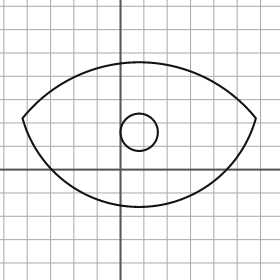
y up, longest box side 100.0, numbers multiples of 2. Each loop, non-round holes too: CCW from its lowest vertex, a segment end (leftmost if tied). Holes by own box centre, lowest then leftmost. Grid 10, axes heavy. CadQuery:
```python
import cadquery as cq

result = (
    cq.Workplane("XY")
    .moveTo(-42.0, 22.0)
    .threePointArc((8.0, -16.0), (58.0, 22.0))
    .threePointArc((8.0, 46.0), (-42.0, 22.0))
    .close()
    .moveTo(8.0, 16.0)
    .circle(8.0)
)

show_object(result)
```